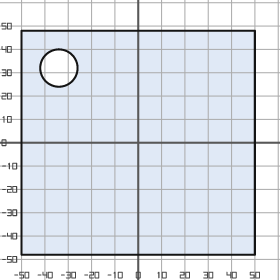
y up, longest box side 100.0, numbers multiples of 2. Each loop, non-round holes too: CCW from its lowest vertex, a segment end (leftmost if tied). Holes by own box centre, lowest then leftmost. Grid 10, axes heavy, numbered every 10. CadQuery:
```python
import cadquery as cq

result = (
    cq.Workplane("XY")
    .moveTo(-50.0, -48.0)
    .lineTo(50.0, -48.0)
    .lineTo(50.0, 48.0)
    .lineTo(-50.0, 48.0)
    .close()
    .moveTo(-34.0, 32.0)
    .circle(8.0)
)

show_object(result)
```